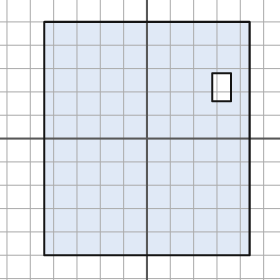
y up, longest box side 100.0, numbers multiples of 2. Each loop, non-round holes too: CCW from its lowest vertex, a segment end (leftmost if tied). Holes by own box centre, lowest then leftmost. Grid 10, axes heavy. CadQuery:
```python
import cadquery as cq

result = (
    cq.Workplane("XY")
    .moveTo(-44.0, -50.0)
    .lineTo(44.0, -50.0)
    .lineTo(44.0, 50.0)
    .lineTo(-44.0, 50.0)
    .close()
    .moveTo(28.0, 16.0)
    .lineTo(36.0, 16.0)
    .lineTo(36.0, 28.0)
    .lineTo(28.0, 28.0)
    .close()
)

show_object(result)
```